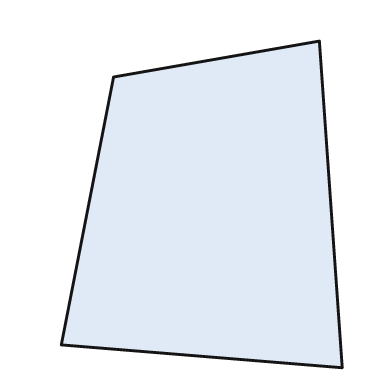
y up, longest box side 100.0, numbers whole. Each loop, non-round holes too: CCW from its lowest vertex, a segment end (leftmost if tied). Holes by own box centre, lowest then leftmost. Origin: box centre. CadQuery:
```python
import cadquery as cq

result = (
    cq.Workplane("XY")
    .moveTo(43.0, -50.0)
    .lineTo(36.0, 50.0)
    .lineTo(-27.0, 39.0)
    .lineTo(-43.0, -43.0)
    .close()
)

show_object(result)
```